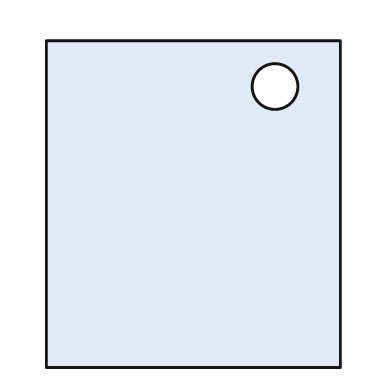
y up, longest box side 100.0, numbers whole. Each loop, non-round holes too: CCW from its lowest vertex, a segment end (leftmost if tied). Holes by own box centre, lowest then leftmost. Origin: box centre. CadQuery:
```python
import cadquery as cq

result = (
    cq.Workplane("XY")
    .moveTo(-45.0, -50.0)
    .lineTo(45.0, -50.0)
    .lineTo(45.0, 50.0)
    .lineTo(-45.0, 50.0)
    .close()
    .moveTo(25.0, 36.0)
    .circle(7.0)
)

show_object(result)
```